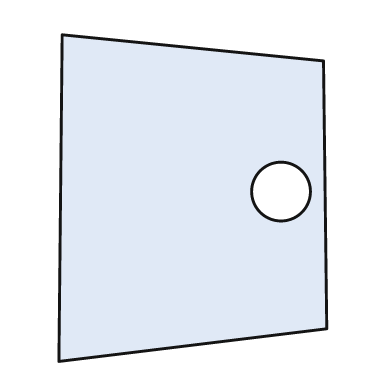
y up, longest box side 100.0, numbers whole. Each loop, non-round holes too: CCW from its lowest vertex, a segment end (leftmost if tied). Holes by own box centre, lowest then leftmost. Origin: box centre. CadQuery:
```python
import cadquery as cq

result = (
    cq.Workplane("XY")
    .moveTo(-41.0, -50.0)
    .lineTo(41.0, -40.0)
    .lineTo(40.0, 42.0)
    .lineTo(-40.0, 50.0)
    .close()
    .moveTo(27.0, 2.0)
    .circle(9.0)
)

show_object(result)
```